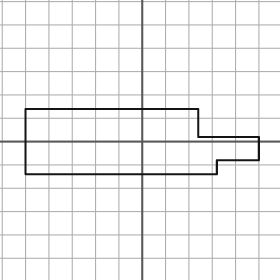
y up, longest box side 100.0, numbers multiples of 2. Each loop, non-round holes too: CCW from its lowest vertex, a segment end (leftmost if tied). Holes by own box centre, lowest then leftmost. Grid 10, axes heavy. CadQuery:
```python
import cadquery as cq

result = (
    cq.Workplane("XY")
    .moveTo(-50.0, -14.0)
    .lineTo(32.0, -14.0)
    .lineTo(32.0, -8.0)
    .lineTo(50.0, -8.0)
    .lineTo(50.0, 2.0)
    .lineTo(24.0, 2.0)
    .lineTo(24.0, 14.0)
    .lineTo(-50.0, 14.0)
    .close()
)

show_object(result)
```